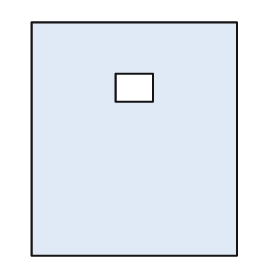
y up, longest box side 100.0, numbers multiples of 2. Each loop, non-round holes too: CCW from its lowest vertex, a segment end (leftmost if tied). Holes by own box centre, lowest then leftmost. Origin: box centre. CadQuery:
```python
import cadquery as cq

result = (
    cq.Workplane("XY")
    .moveTo(-44.0, -50.0)
    .lineTo(44.0, -50.0)
    .lineTo(44.0, 50.0)
    .lineTo(-44.0, 50.0)
    .close()
    .moveTo(-8.0, 16.0)
    .lineTo(8.0, 16.0)
    .lineTo(8.0, 28.0)
    .lineTo(-8.0, 28.0)
    .close()
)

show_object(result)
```